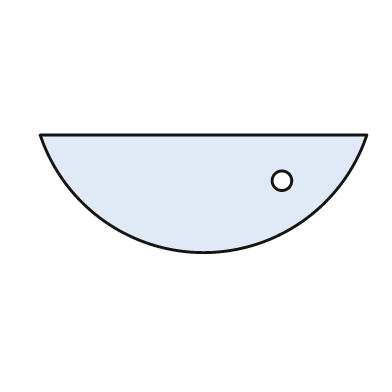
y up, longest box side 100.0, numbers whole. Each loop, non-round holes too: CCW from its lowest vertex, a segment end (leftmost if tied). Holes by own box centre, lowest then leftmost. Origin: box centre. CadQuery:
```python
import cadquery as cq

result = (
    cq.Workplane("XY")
    .moveTo(-50.0, 18.0)
    .threePointArc((0.0, -18.0), (50.0, 18.0))
    .close()
    .moveTo(24.0, 4.0)
    .circle(3.0)
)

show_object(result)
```